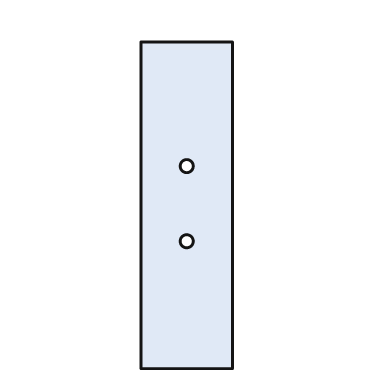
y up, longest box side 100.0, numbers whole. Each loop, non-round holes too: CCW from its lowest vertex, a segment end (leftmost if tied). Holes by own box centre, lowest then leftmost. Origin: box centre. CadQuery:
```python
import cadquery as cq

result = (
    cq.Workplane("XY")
    .moveTo(-14.0, -50.0)
    .lineTo(14.0, -50.0)
    .lineTo(14.0, 50.0)
    .lineTo(-14.0, 50.0)
    .close()
    .moveTo(0.0, -11.0)
    .circle(2.0)
    .moveTo(0.0, 12.0)
    .circle(2.0)
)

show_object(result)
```